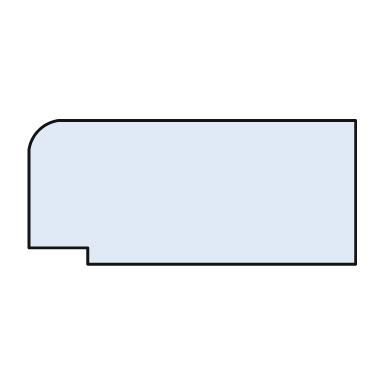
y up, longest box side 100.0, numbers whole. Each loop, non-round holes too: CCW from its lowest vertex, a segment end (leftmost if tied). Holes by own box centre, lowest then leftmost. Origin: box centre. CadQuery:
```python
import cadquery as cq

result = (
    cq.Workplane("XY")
    .moveTo(-32.0, -22.0)
    .lineTo(50.0, -22.0)
    .lineTo(50.0, 22.0)
    .lineTo(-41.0, 22.0)
    .threePointArc((-47.0, 19.0), (-50.0, 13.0))
    .lineTo(-50.0, -17.0)
    .lineTo(-32.0, -17.0)
    .close()
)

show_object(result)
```